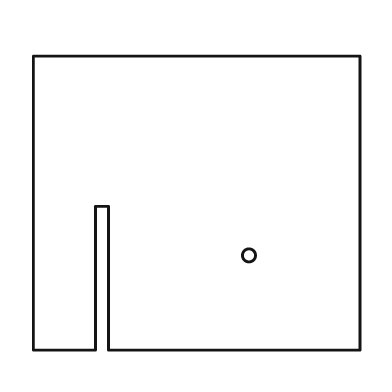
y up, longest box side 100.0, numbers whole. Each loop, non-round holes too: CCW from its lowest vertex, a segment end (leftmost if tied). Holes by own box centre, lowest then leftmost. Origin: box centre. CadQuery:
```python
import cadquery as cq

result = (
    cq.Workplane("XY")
    .moveTo(-50.0, -45.0)
    .lineTo(-31.0, -45.0)
    .lineTo(-31.0, -1.0)
    .lineTo(-27.0, -1.0)
    .lineTo(-27.0, -45.0)
    .lineTo(50.0, -45.0)
    .lineTo(50.0, 45.0)
    .lineTo(-50.0, 45.0)
    .close()
    .moveTo(16.0, -16.0)
    .circle(2.0)
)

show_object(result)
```